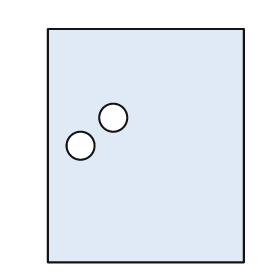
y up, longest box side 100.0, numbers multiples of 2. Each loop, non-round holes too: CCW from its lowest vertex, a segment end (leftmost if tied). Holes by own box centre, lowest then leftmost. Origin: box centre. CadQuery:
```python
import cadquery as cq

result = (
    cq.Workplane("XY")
    .moveTo(-42.0, -50.0)
    .lineTo(42.0, -50.0)
    .lineTo(42.0, 50.0)
    .lineTo(-42.0, 50.0)
    .close()
    .moveTo(-28.0, 0.0)
    .circle(6.0)
    .moveTo(-14.0, 12.0)
    .circle(6.0)
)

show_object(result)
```